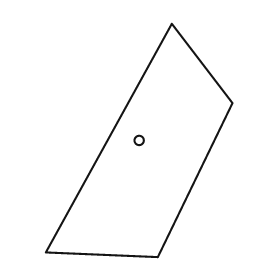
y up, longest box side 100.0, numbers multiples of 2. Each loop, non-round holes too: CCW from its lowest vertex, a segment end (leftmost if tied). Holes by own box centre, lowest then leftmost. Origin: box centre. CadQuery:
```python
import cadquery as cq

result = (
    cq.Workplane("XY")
    .moveTo(8.0, -50.0)
    .lineTo(40.0, 16.0)
    .lineTo(14.0, 50.0)
    .lineTo(-40.0, -48.0)
    .close()
    .moveTo(0.0, 0.0)
    .circle(2.0)
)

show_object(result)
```